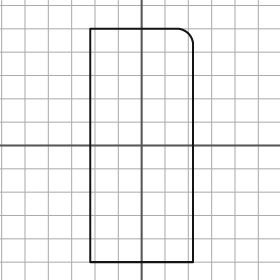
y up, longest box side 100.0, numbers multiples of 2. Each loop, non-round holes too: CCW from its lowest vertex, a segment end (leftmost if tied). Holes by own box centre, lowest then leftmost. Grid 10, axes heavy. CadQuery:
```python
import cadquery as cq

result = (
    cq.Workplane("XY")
    .moveTo(-22.0, -50.0)
    .lineTo(22.0, -50.0)
    .lineTo(22.0, 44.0)
    .threePointArc((20.0, 48.0), (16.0, 50.0))
    .lineTo(-22.0, 50.0)
    .close()
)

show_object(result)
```